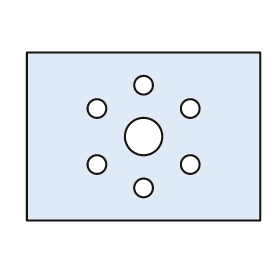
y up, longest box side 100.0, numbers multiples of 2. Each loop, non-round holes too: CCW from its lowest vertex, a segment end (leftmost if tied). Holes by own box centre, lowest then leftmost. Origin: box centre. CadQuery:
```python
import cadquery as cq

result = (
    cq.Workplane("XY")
    .moveTo(-50.0, -36.0)
    .lineTo(50.0, -36.0)
    .lineTo(50.0, 36.0)
    .lineTo(-50.0, 36.0)
    .close()
    .moveTo(0.0, -22.0)
    .circle(4.0)
    .moveTo(-20.0, -12.0)
    .circle(4.0)
    .moveTo(20.0, -12.0)
    .circle(4.0)
    .moveTo(0.0, 0.0)
    .circle(8.0)
    .moveTo(-20.0, 12.0)
    .circle(4.0)
    .moveTo(20.0, 12.0)
    .circle(4.0)
    .moveTo(0.0, 22.0)
    .circle(4.0)
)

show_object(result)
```